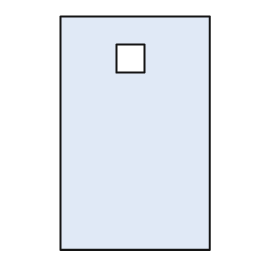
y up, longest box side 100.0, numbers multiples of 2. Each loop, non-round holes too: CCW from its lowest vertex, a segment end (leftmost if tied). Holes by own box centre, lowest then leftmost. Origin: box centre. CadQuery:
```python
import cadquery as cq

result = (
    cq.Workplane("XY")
    .moveTo(-32.0, -50.0)
    .lineTo(32.0, -50.0)
    .lineTo(32.0, 50.0)
    .lineTo(-32.0, 50.0)
    .close()
    .moveTo(-8.0, 26.0)
    .lineTo(4.0, 26.0)
    .lineTo(4.0, 38.0)
    .lineTo(-8.0, 38.0)
    .close()
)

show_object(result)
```